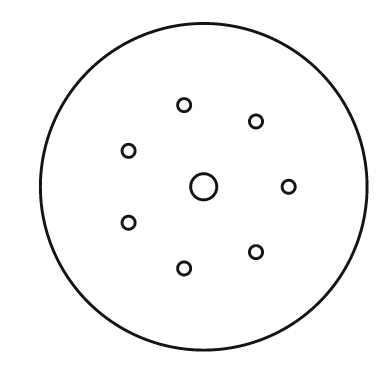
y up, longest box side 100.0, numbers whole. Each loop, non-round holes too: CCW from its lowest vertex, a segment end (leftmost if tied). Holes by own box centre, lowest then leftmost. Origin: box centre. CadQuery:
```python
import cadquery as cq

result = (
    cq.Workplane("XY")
    .moveTo(0.0, 0.0)
    .circle(50.0)
    .moveTo(-6.0, -25.0)
    .circle(2.0)
    .moveTo(16.0, -20.0)
    .circle(2.0)
    .moveTo(-23.0, -11.0)
    .circle(2.0)
    .moveTo(0.0, 0.0)
    .circle(4.0)
    .moveTo(26.0, 0.0)
    .circle(2.0)
    .moveTo(-23.0, 11.0)
    .circle(2.0)
    .moveTo(16.0, 20.0)
    .circle(2.0)
    .moveTo(-6.0, 25.0)
    .circle(2.0)
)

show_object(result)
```